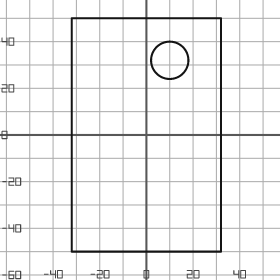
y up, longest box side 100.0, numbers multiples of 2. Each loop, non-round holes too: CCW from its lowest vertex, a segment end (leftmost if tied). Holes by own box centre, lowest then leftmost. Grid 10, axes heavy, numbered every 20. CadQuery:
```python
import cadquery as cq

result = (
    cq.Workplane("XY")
    .moveTo(-32.0, -50.0)
    .lineTo(32.0, -50.0)
    .lineTo(32.0, 50.0)
    .lineTo(-32.0, 50.0)
    .close()
    .moveTo(10.0, 32.0)
    .circle(8.0)
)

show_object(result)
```